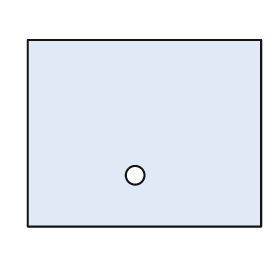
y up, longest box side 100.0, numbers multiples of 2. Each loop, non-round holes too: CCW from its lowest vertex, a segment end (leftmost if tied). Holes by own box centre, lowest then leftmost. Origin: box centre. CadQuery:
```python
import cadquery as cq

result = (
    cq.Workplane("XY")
    .moveTo(-50.0, -40.0)
    .lineTo(50.0, -40.0)
    .lineTo(50.0, 40.0)
    .lineTo(-50.0, 40.0)
    .close()
    .moveTo(-4.0, -18.0)
    .circle(4.0)
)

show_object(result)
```